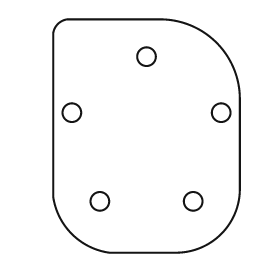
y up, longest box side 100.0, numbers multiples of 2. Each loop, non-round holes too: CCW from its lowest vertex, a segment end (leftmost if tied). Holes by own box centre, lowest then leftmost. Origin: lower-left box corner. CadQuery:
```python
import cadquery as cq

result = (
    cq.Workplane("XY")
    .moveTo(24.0, 0.0)
    .lineTo(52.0, 0.0)
    .threePointArc((72.0, 8.0), (80.0, 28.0))
    .lineTo(80.0, 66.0)
    .threePointArc((70.0, 90.0), (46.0, 100.0))
    .lineTo(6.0, 100.0)
    .threePointArc((2.0, 98.0), (0.0, 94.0))
    .lineTo(0.0, 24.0)
    .threePointArc((8.0, 8.0), (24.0, 0.0))
    .close()
    .moveTo(20.0, 22.0)
    .circle(4.0)
    .moveTo(60.0, 22.0)
    .circle(4.0)
    .moveTo(8.0, 60.0)
    .circle(4.0)
    .moveTo(72.0, 60.0)
    .circle(4.0)
    .moveTo(40.0, 84.0)
    .circle(4.0)
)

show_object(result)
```